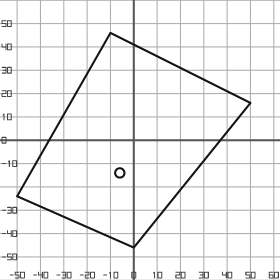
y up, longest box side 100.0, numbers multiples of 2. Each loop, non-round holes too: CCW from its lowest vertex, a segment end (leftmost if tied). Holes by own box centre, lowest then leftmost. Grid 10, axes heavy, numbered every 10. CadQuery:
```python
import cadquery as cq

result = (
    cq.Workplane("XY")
    .moveTo(0.0, -46.0)
    .lineTo(50.0, 16.0)
    .lineTo(-10.0, 46.0)
    .lineTo(-50.0, -24.0)
    .close()
    .moveTo(-6.0, -14.0)
    .circle(2.0)
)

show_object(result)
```